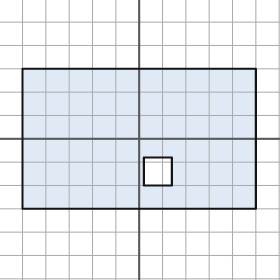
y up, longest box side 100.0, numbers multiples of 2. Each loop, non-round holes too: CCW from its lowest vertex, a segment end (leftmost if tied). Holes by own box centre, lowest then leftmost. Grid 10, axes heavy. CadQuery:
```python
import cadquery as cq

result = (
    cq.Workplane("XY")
    .moveTo(-50.0, -30.0)
    .lineTo(50.0, -30.0)
    .lineTo(50.0, 30.0)
    .lineTo(-50.0, 30.0)
    .close()
    .moveTo(2.0, -20.0)
    .lineTo(14.0, -20.0)
    .lineTo(14.0, -8.0)
    .lineTo(2.0, -8.0)
    .close()
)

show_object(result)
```